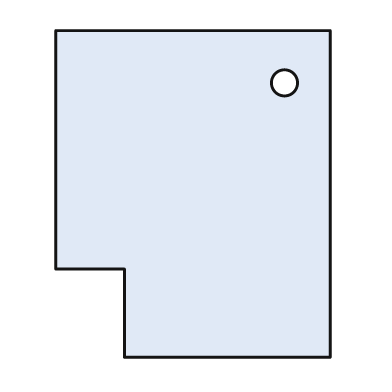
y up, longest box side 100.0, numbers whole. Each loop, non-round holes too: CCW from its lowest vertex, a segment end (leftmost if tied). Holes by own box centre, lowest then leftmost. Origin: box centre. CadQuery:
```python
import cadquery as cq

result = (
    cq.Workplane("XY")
    .moveTo(-21.0, -50.0)
    .lineTo(42.0, -50.0)
    .lineTo(42.0, 50.0)
    .lineTo(-42.0, 50.0)
    .lineTo(-42.0, -23.0)
    .lineTo(-21.0, -23.0)
    .close()
    .moveTo(28.0, 34.0)
    .circle(4.0)
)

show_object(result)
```